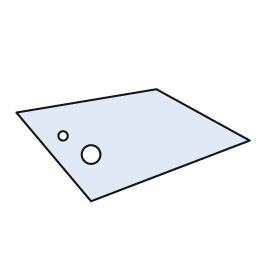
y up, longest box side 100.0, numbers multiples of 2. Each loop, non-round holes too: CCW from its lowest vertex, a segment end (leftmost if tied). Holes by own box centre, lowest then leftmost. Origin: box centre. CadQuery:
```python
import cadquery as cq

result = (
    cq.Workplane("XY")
    .moveTo(-18.0, -24.0)
    .lineTo(50.0, 2.0)
    .lineTo(10.0, 24.0)
    .lineTo(-50.0, 14.0)
    .close()
    .moveTo(-18.0, -4.0)
    .circle(4.0)
    .moveTo(-30.0, 4.0)
    .circle(2.0)
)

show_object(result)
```